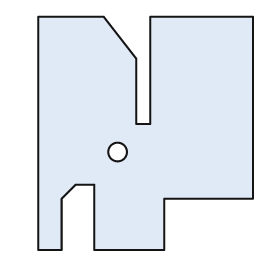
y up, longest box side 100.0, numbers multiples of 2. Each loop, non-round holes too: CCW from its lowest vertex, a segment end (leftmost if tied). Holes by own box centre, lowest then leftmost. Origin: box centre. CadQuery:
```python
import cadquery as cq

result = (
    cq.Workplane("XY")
    .moveTo(-46.0, -50.0)
    .lineTo(-36.0, -50.0)
    .lineTo(-36.0, -28.0)
    .lineTo(-30.0, -22.0)
    .lineTo(-22.0, -22.0)
    .lineTo(-22.0, -50.0)
    .lineTo(8.0, -50.0)
    .lineTo(8.0, -28.0)
    .lineTo(46.0, -28.0)
    .lineTo(46.0, 50.0)
    .lineTo(2.0, 50.0)
    .lineTo(2.0, 4.0)
    .lineTo(-4.0, 4.0)
    .lineTo(-4.0, 32.0)
    .lineTo(-18.0, 50.0)
    .lineTo(-46.0, 50.0)
    .close()
    .moveTo(-12.0, -8.0)
    .circle(4.0)
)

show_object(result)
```